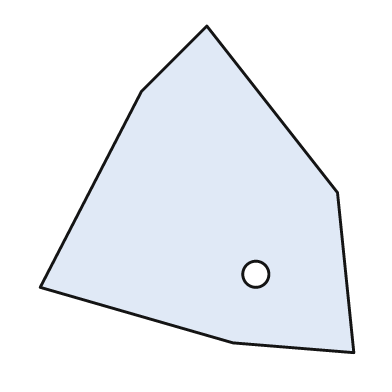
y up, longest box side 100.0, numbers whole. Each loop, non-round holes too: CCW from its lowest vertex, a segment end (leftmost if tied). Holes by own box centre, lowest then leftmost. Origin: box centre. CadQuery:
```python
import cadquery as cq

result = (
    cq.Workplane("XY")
    .moveTo(48.0, -50.0)
    .lineTo(43.0, -1.0)
    .lineTo(3.0, 50.0)
    .lineTo(-17.0, 30.0)
    .lineTo(-48.0, -30.0)
    .lineTo(11.0, -47.0)
    .close()
    .moveTo(18.0, -26.0)
    .circle(4.0)
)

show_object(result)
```